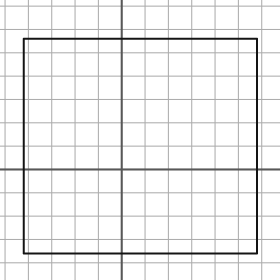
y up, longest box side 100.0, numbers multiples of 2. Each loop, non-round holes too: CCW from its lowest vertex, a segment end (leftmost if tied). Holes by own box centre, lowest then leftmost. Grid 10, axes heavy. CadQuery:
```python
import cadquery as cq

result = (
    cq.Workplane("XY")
    .moveTo(-42.0, -36.0)
    .lineTo(58.0, -36.0)
    .lineTo(58.0, 56.0)
    .lineTo(-42.0, 56.0)
    .close()
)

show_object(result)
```